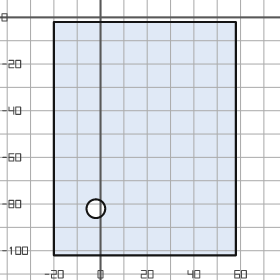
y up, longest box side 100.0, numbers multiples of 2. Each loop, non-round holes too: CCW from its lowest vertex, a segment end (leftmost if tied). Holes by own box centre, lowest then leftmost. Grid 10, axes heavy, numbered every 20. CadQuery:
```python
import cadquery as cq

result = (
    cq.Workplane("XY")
    .moveTo(-20.0, -102.0)
    .lineTo(58.0, -102.0)
    .lineTo(58.0, -2.0)
    .lineTo(-20.0, -2.0)
    .close()
    .moveTo(-2.0, -82.0)
    .circle(4.0)
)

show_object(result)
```